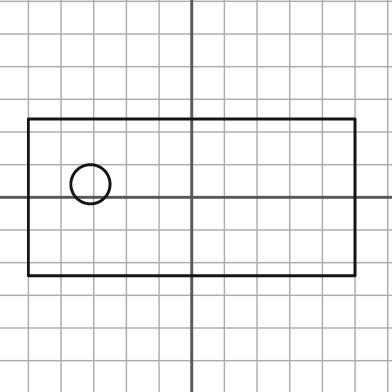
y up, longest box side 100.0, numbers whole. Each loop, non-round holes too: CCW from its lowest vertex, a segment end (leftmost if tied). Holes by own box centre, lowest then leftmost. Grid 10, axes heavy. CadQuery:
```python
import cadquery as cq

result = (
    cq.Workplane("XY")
    .moveTo(-50.0, -24.0)
    .lineTo(50.0, -24.0)
    .lineTo(50.0, 24.0)
    .lineTo(-50.0, 24.0)
    .close()
    .moveTo(-31.0, 4.0)
    .circle(6.0)
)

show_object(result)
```